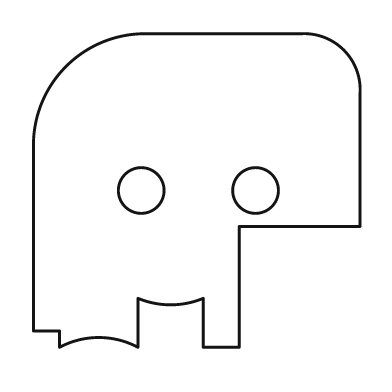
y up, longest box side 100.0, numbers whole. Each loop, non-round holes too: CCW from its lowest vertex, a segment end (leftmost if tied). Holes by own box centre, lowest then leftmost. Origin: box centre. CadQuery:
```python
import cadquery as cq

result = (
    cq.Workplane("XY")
    .moveTo(-42.0, -48.0)
    .threePointArc((-30.0, -45.0), (-18.0, -48.0))
    .lineTo(-18.0, -33.0)
    .threePointArc((-8.0, -35.0), (2.0, -33.0))
    .lineTo(2.0, -48.0)
    .lineTo(13.0, -48.0)
    .lineTo(13.0, -11.0)
    .lineTo(50.0, -11.0)
    .lineTo(50.0, 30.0)
    .threePointArc((45.0, 43.0), (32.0, 48.0))
    .lineTo(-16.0, 48.0)
    .threePointArc((-40.0, 38.0), (-50.0, 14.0))
    .lineTo(-50.0, -43.0)
    .lineTo(-42.0, -43.0)
    .close()
    .moveTo(-17.0, 0.0)
    .circle(7.0)
    .moveTo(18.0, 0.0)
    .circle(7.0)
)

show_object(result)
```